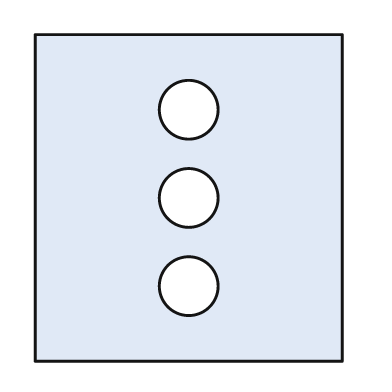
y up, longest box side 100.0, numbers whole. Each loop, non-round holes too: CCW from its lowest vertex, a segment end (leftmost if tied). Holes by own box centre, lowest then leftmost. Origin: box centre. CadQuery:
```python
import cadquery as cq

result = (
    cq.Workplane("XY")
    .moveTo(-47.0, -50.0)
    .lineTo(47.0, -50.0)
    .lineTo(47.0, 50.0)
    .lineTo(-47.0, 50.0)
    .close()
    .moveTo(0.0, -27.0)
    .circle(9.0)
    .moveTo(0.0, 0.0)
    .circle(9.0)
    .moveTo(0.0, 27.0)
    .circle(9.0)
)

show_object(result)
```